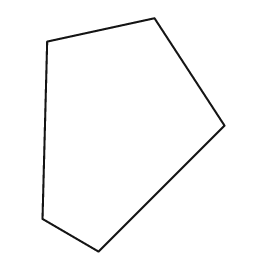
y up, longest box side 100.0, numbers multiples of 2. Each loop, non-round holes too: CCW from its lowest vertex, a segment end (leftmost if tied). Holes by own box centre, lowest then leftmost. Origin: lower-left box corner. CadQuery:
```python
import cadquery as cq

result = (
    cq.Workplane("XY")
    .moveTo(24.0, 0.0)
    .lineTo(78.0, 54.0)
    .lineTo(48.0, 100.0)
    .lineTo(2.0, 90.0)
    .lineTo(0.0, 14.0)
    .close()
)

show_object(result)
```